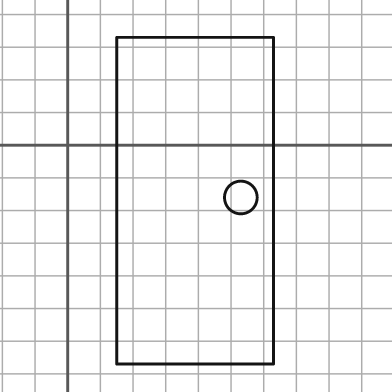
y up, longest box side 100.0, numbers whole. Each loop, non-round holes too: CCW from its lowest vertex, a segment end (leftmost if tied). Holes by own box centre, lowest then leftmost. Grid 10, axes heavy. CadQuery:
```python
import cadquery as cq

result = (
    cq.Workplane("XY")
    .moveTo(15.0, -67.0)
    .lineTo(63.0, -67.0)
    .lineTo(63.0, 33.0)
    .lineTo(15.0, 33.0)
    .close()
    .moveTo(53.0, -16.0)
    .circle(5.0)
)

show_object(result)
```